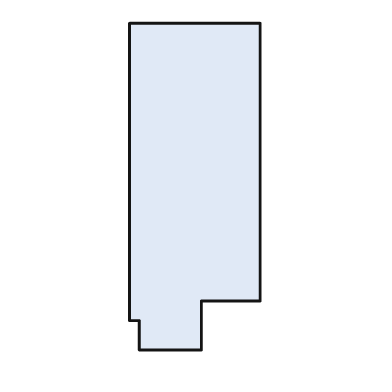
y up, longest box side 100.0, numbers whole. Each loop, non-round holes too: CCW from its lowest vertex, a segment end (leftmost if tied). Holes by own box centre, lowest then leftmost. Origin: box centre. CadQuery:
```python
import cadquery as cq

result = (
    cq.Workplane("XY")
    .moveTo(-17.0, -50.0)
    .lineTo(2.0, -50.0)
    .lineTo(2.0, -35.0)
    .lineTo(20.0, -35.0)
    .lineTo(20.0, 50.0)
    .lineTo(-20.0, 50.0)
    .lineTo(-20.0, -41.0)
    .lineTo(-17.0, -41.0)
    .close()
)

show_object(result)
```